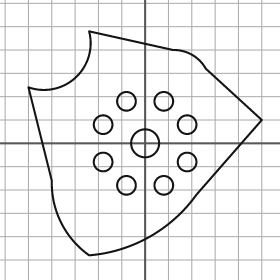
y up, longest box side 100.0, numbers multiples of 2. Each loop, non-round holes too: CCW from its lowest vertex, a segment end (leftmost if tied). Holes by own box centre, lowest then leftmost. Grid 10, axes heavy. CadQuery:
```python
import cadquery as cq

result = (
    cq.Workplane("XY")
    .moveTo(-24.0, -48.0)
    .threePointArc((2.0, -40.0), (22.0, -22.0))
    .lineTo(50.0, 10.0)
    .lineTo(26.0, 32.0)
    .threePointArc((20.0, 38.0), (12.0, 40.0))
    .lineTo(-24.0, 48.0)
    .threePointArc((-30.0, 28.0), (-50.0, 24.0))
    .lineTo(-40.0, -16.0)
    .threePointArc((-36.0, -34.0), (-24.0, -48.0))
    .close()
    .moveTo(-8.0, -18.0)
    .circle(4.0)
    .moveTo(8.0, -18.0)
    .circle(4.0)
    .moveTo(-18.0, -8.0)
    .circle(4.0)
    .moveTo(18.0, -8.0)
    .circle(4.0)
    .moveTo(0.0, 0.0)
    .circle(6.0)
    .moveTo(-18.0, 8.0)
    .circle(4.0)
    .moveTo(18.0, 8.0)
    .circle(4.0)
    .moveTo(-8.0, 18.0)
    .circle(4.0)
    .moveTo(8.0, 18.0)
    .circle(4.0)
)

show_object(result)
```